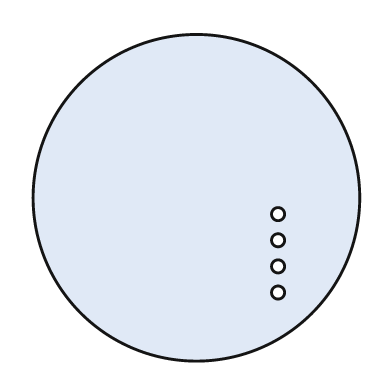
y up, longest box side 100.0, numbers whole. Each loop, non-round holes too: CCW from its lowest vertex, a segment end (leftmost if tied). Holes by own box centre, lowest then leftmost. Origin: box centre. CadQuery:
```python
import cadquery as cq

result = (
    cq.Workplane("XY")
    .moveTo(0.0, 0.0)
    .circle(50.0)
    .moveTo(25.0, -29.0)
    .circle(2.0)
    .moveTo(25.0, -21.0)
    .circle(2.0)
    .moveTo(25.0, -13.0)
    .circle(2.0)
    .moveTo(25.0, -5.0)
    .circle(2.0)
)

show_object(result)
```